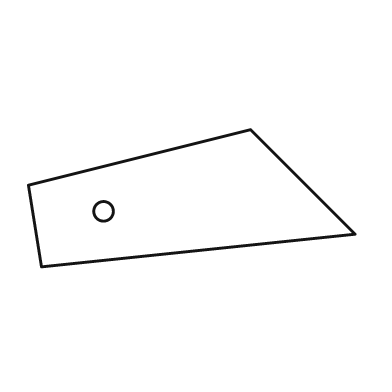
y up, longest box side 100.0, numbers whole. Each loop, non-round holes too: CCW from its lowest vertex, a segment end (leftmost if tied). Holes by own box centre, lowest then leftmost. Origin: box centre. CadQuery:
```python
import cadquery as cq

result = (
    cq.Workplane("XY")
    .moveTo(-46.0, -21.0)
    .lineTo(50.0, -11.0)
    .lineTo(18.0, 21.0)
    .lineTo(-50.0, 4.0)
    .close()
    .moveTo(-27.0, -4.0)
    .circle(3.0)
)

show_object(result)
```